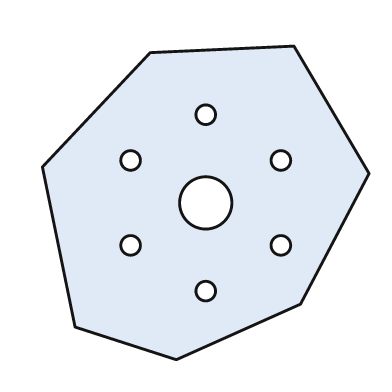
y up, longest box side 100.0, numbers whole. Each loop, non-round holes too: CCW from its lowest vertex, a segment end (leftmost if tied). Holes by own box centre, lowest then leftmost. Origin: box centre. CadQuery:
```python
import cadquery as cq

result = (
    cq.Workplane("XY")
    .moveTo(-9.0, -48.0)
    .lineTo(29.0, -31.0)
    .lineTo(50.0, 9.0)
    .lineTo(27.0, 48.0)
    .lineTo(-17.0, 46.0)
    .lineTo(-50.0, 11.0)
    .lineTo(-40.0, -38.0)
    .close()
    .moveTo(0.0, -27.0)
    .circle(3.0)
    .moveTo(-23.0, -13.0)
    .circle(3.0)
    .moveTo(23.0, -13.0)
    .circle(3.0)
    .moveTo(0.0, 0.0)
    .circle(8.0)
    .moveTo(-23.0, 13.0)
    .circle(3.0)
    .moveTo(23.0, 13.0)
    .circle(3.0)
    .moveTo(0.0, 27.0)
    .circle(3.0)
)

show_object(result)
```